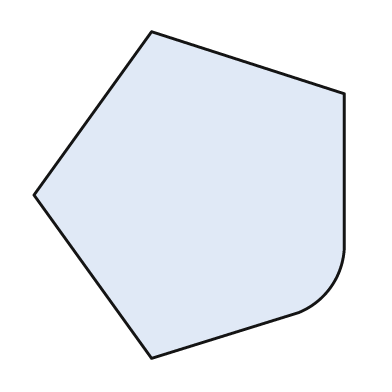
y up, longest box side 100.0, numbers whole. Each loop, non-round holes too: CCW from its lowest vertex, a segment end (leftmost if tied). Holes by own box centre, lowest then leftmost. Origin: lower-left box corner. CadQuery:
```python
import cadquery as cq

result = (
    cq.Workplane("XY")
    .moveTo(36.0, 0.0)
    .lineTo(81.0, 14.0)
    .threePointArc((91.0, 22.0), (95.0, 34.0))
    .lineTo(95.0, 81.0)
    .lineTo(36.0, 100.0)
    .lineTo(0.0, 50.0)
    .close()
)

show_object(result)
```